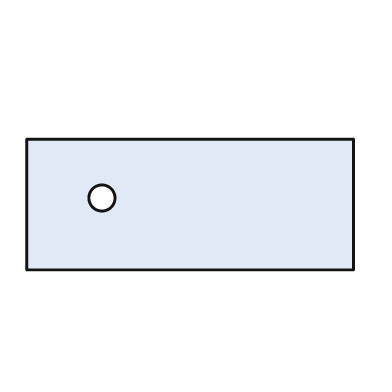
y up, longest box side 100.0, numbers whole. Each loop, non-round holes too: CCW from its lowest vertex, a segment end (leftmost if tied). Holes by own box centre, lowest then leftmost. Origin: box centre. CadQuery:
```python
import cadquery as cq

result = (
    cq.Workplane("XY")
    .moveTo(-50.0, -20.0)
    .lineTo(50.0, -20.0)
    .lineTo(50.0, 20.0)
    .lineTo(-50.0, 20.0)
    .close()
    .moveTo(-27.0, 2.0)
    .circle(4.0)
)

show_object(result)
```